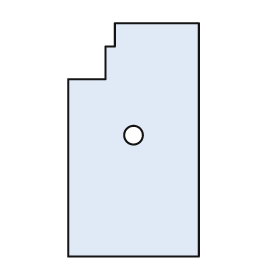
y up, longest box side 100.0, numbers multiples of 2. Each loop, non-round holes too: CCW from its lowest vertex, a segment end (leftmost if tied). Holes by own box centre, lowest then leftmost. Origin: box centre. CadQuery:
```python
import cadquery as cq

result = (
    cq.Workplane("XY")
    .moveTo(-28.0, -50.0)
    .lineTo(28.0, -50.0)
    .lineTo(28.0, 50.0)
    .lineTo(-8.0, 50.0)
    .lineTo(-8.0, 40.0)
    .lineTo(-12.0, 40.0)
    .lineTo(-12.0, 26.0)
    .lineTo(-28.0, 26.0)
    .close()
    .moveTo(0.0, 2.0)
    .circle(4.0)
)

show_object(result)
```